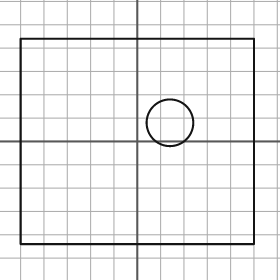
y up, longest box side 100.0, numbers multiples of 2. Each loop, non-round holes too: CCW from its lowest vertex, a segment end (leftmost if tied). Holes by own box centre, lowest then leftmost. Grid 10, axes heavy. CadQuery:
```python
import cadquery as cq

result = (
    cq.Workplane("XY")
    .moveTo(-50.0, -44.0)
    .lineTo(50.0, -44.0)
    .lineTo(50.0, 44.0)
    .lineTo(-50.0, 44.0)
    .close()
    .moveTo(14.0, 8.0)
    .circle(10.0)
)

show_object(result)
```